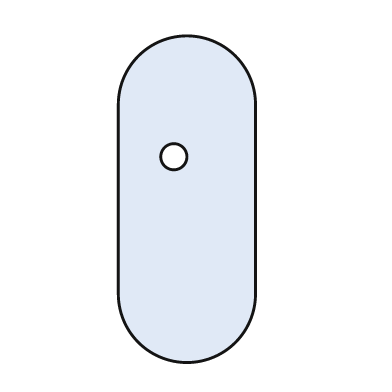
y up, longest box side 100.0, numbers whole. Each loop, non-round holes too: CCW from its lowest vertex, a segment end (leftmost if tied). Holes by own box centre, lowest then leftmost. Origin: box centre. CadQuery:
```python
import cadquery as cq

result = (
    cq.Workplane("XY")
    .moveTo(-21.0, -29.0)
    .threePointArc((0.0, -50.0), (21.0, -29.0))
    .lineTo(21.0, 29.0)
    .threePointArc((0.0, 50.0), (-21.0, 29.0))
    .close()
    .moveTo(-4.0, 13.0)
    .circle(4.0)
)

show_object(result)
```